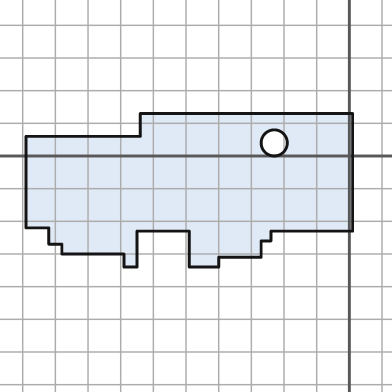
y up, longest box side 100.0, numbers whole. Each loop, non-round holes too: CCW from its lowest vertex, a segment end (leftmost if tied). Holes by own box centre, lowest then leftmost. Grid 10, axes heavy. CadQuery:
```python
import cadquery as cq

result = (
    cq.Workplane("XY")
    .moveTo(-69.0, -34.0)
    .lineTo(-65.0, -34.0)
    .lineTo(-65.0, -23.0)
    .lineTo(-49.0, -23.0)
    .lineTo(-49.0, -34.0)
    .lineTo(-40.0, -34.0)
    .lineTo(-40.0, -31.0)
    .lineTo(-27.0, -31.0)
    .lineTo(-27.0, -26.0)
    .lineTo(-24.0, -26.0)
    .lineTo(-24.0, -23.0)
    .lineTo(1.0, -23.0)
    .lineTo(1.0, 13.0)
    .lineTo(-64.0, 13.0)
    .lineTo(-64.0, 6.0)
    .lineTo(-99.0, 6.0)
    .lineTo(-99.0, -22.0)
    .lineTo(-92.0, -22.0)
    .lineTo(-92.0, -27.0)
    .lineTo(-88.0, -27.0)
    .lineTo(-88.0, -30.0)
    .lineTo(-69.0, -30.0)
    .close()
    .moveTo(-23.0, 4.0)
    .circle(4.0)
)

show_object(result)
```